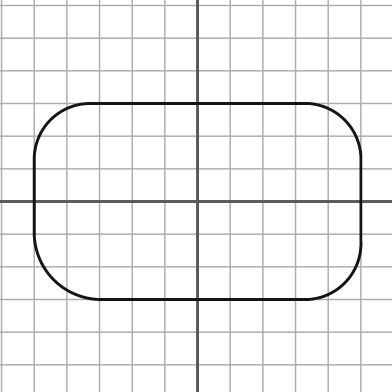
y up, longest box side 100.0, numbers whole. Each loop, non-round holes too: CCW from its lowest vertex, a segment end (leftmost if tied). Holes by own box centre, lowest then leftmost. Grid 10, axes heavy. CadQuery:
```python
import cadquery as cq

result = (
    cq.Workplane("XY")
    .moveTo(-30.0, -30.0)
    .lineTo(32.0, -30.0)
    .threePointArc((45.0, -25.0), (50.0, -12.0))
    .lineTo(50.0, 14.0)
    .threePointArc((45.0, 25.0), (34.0, 30.0))
    .lineTo(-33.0, 30.0)
    .threePointArc((-45.0, 25.0), (-50.0, 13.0))
    .lineTo(-50.0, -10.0)
    .threePointArc((-44.0, -24.0), (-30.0, -30.0))
    .close()
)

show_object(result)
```